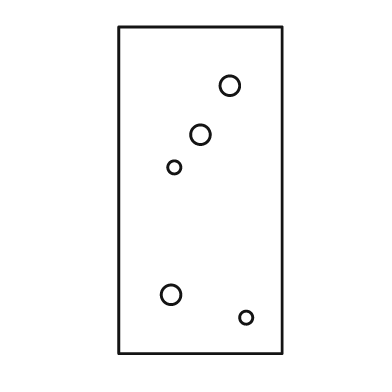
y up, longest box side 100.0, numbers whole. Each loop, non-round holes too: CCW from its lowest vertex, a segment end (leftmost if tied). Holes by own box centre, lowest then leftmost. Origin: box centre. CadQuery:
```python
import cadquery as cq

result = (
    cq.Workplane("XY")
    .moveTo(-25.0, -50.0)
    .lineTo(25.0, -50.0)
    .lineTo(25.0, 50.0)
    .lineTo(-25.0, 50.0)
    .close()
    .moveTo(14.0, -39.0)
    .circle(2.0)
    .moveTo(-9.0, -32.0)
    .circle(3.0)
    .moveTo(-8.0, 7.0)
    .circle(2.0)
    .moveTo(0.0, 17.0)
    .circle(3.0)
    .moveTo(9.0, 32.0)
    .circle(3.0)
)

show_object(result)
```